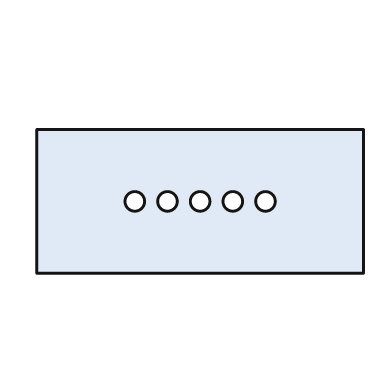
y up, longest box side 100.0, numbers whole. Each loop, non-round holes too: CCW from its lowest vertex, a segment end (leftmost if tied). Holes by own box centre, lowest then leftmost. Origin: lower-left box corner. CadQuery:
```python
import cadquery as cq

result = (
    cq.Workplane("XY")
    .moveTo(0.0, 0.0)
    .lineTo(100.0, 0.0)
    .lineTo(100.0, 44.0)
    .lineTo(0.0, 44.0)
    .close()
    .moveTo(30.0, 22.0)
    .circle(3.0)
    .moveTo(40.0, 22.0)
    .circle(3.0)
    .moveTo(50.0, 22.0)
    .circle(3.0)
    .moveTo(60.0, 22.0)
    .circle(3.0)
    .moveTo(70.0, 22.0)
    .circle(3.0)
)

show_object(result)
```